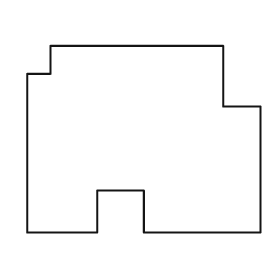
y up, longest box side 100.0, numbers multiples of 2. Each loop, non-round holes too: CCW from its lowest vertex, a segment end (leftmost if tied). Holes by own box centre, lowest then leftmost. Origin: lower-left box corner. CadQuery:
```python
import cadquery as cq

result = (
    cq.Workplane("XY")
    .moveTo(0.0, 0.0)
    .lineTo(30.0, 0.0)
    .lineTo(30.0, 18.0)
    .lineTo(50.0, 18.0)
    .lineTo(50.0, 0.0)
    .lineTo(100.0, 0.0)
    .lineTo(100.0, 54.0)
    .lineTo(84.0, 54.0)
    .lineTo(84.0, 80.0)
    .lineTo(10.0, 80.0)
    .lineTo(10.0, 68.0)
    .lineTo(0.0, 68.0)
    .close()
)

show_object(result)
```